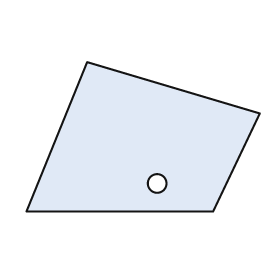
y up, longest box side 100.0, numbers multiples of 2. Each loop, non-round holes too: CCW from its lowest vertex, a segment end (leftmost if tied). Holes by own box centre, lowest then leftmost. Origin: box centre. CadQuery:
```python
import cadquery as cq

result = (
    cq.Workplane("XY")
    .moveTo(-50.0, -32.0)
    .lineTo(30.0, -32.0)
    .lineTo(50.0, 10.0)
    .lineTo(-24.0, 32.0)
    .close()
    .moveTo(6.0, -20.0)
    .circle(4.0)
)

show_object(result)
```